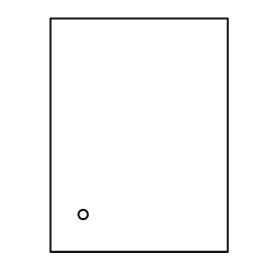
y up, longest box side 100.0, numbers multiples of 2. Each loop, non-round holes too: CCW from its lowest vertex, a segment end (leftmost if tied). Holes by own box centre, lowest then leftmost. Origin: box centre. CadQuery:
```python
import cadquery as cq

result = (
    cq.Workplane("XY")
    .moveTo(-38.0, -50.0)
    .lineTo(38.0, -50.0)
    .lineTo(38.0, 50.0)
    .lineTo(-38.0, 50.0)
    .close()
    .moveTo(-24.0, -34.0)
    .circle(2.0)
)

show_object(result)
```